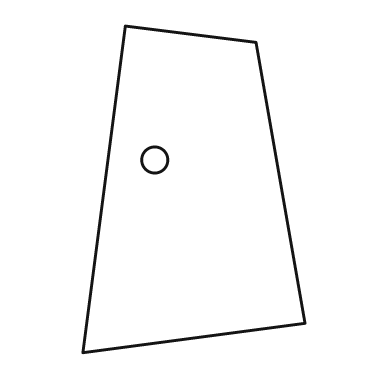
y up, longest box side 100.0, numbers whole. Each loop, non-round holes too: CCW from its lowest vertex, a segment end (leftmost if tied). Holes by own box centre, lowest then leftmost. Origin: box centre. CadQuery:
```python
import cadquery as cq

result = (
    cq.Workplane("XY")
    .moveTo(-34.0, -50.0)
    .lineTo(34.0, -41.0)
    .lineTo(19.0, 45.0)
    .lineTo(-21.0, 50.0)
    .close()
    .moveTo(-12.0, 9.0)
    .circle(4.0)
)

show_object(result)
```